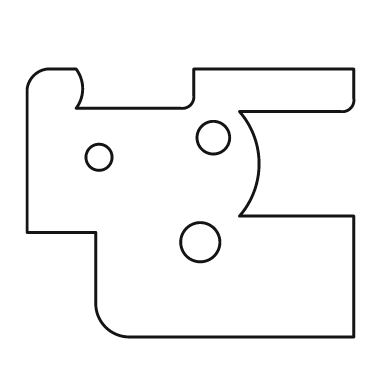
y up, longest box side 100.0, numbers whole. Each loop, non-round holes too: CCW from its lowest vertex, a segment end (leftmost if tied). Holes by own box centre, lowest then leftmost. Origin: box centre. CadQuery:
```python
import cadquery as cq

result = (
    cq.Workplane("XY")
    .moveTo(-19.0, -41.0)
    .lineTo(50.0, -41.0)
    .lineTo(50.0, -4.0)
    .lineTo(15.0, -4.0)
    .threePointArc((21.0, 12.0), (15.0, 28.0))
    .lineTo(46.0, 28.0)
    .threePointArc((49.0, 29.0), (50.0, 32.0))
    .lineTo(50.0, 41.0)
    .lineTo(1.0, 41.0)
    .lineTo(1.0, 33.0)
    .threePointArc((0.0, 30.0), (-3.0, 29.0))
    .lineTo(-35.0, 29.0)
    .threePointArc((-33.0, 35.0), (-35.0, 41.0))
    .lineTo(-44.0, 41.0)
    .threePointArc((-48.0, 39.0), (-50.0, 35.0))
    .lineTo(-50.0, -9.0)
    .lineTo(-29.0, -9.0)
    .lineTo(-29.0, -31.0)
    .threePointArc((-26.0, -38.0), (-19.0, -41.0))
    .close()
    .moveTo(3.0, -12.0)
    .circle(6.0)
    .moveTo(-28.0, 14.0)
    .circle(4.0)
    .moveTo(7.0, 20.0)
    .circle(5.0)
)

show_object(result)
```